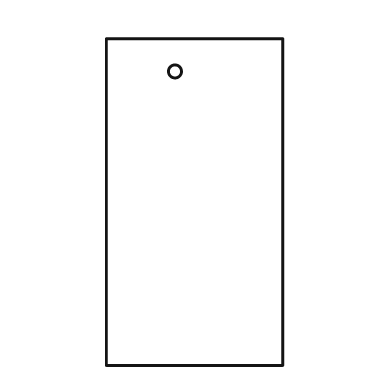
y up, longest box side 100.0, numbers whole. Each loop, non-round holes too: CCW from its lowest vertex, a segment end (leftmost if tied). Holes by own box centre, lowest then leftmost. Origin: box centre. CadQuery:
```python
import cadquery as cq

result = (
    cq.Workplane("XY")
    .moveTo(-27.0, -50.0)
    .lineTo(27.0, -50.0)
    .lineTo(27.0, 50.0)
    .lineTo(-27.0, 50.0)
    .close()
    .moveTo(-6.0, 40.0)
    .circle(2.0)
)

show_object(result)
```